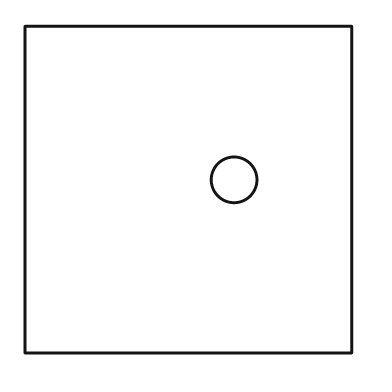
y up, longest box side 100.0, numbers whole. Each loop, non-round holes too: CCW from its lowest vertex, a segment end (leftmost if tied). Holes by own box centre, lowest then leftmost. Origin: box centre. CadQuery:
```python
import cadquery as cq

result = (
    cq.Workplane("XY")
    .moveTo(-50.0, -50.0)
    .lineTo(50.0, -50.0)
    .lineTo(50.0, 50.0)
    .lineTo(-50.0, 50.0)
    .close()
    .moveTo(14.0, 3.0)
    .circle(7.0)
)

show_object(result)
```